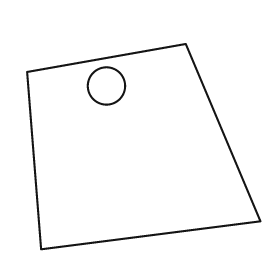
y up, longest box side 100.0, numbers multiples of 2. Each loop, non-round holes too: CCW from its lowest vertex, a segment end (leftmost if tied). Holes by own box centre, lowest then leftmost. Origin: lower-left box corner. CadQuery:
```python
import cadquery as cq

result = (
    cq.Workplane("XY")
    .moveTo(6.0, 0.0)
    .lineTo(100.0, 12.0)
    .lineTo(68.0, 88.0)
    .lineTo(0.0, 76.0)
    .close()
    .moveTo(34.0, 70.0)
    .circle(8.0)
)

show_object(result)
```